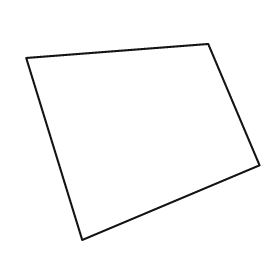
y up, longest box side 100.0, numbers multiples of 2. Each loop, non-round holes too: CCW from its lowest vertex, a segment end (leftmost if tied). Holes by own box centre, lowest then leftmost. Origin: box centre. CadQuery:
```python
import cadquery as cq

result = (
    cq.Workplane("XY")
    .moveTo(-26.0, -42.0)
    .lineTo(50.0, -10.0)
    .lineTo(28.0, 42.0)
    .lineTo(-50.0, 36.0)
    .close()
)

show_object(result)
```